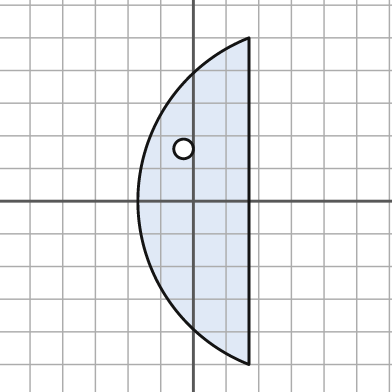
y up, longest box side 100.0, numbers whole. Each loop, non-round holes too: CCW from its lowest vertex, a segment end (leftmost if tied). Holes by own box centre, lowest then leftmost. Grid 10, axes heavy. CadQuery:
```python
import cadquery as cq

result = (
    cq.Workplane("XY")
    .moveTo(17.0, -50.0)
    .lineTo(17.0, 50.0)
    .threePointArc((-17.0, 0.0), (17.0, -50.0))
    .close()
    .moveTo(-3.0, 16.0)
    .circle(3.0)
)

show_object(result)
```